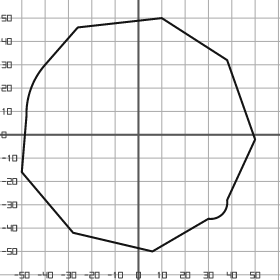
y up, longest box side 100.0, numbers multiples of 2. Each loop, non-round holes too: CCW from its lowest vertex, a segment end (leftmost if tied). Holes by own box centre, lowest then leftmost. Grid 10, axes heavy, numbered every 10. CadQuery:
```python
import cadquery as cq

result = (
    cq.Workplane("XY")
    .moveTo(6.0, -50.0)
    .lineTo(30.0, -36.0)
    .threePointArc((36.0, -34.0), (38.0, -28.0))
    .lineTo(50.0, -2.0)
    .lineTo(38.0, 32.0)
    .lineTo(10.0, 50.0)
    .lineTo(-26.0, 46.0)
    .lineTo(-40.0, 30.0)
    .threePointArc((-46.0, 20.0), (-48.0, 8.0))
    .lineTo(-50.0, -16.0)
    .lineTo(-28.0, -42.0)
    .close()
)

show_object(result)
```